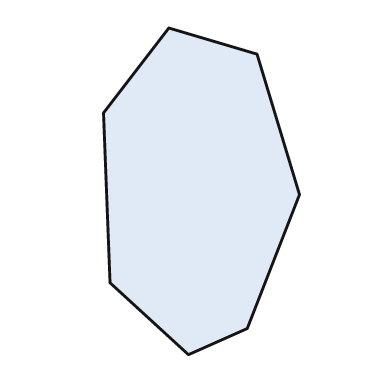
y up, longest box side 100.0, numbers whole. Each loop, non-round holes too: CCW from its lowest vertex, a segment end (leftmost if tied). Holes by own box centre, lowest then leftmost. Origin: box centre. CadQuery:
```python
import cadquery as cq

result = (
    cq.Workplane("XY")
    .moveTo(-4.0, -50.0)
    .lineTo(14.0, -42.0)
    .lineTo(30.0, -1.0)
    .lineTo(17.0, 42.0)
    .lineTo(-10.0, 50.0)
    .lineTo(-30.0, 24.0)
    .lineTo(-28.0, -28.0)
    .close()
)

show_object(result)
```